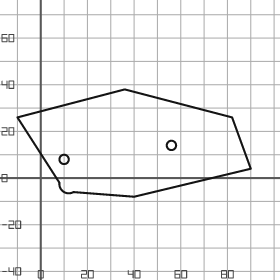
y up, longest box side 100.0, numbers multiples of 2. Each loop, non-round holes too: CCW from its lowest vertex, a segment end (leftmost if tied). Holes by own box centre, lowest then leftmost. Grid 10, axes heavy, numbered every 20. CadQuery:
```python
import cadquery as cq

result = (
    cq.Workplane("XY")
    .moveTo(40.0, -8.0)
    .lineTo(90.0, 4.0)
    .lineTo(82.0, 26.0)
    .lineTo(36.0, 38.0)
    .lineTo(-10.0, 26.0)
    .lineTo(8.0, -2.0)
    .threePointArc((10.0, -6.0), (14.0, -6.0))
    .close()
    .moveTo(10.0, 8.0)
    .circle(2.0)
    .moveTo(56.0, 14.0)
    .circle(2.0)
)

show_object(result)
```